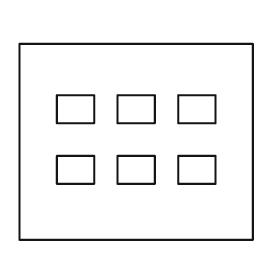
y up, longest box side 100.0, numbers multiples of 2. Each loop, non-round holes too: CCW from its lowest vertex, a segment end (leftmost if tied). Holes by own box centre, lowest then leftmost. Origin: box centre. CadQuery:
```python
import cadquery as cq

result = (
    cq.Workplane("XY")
    .moveTo(-50.0, -42.0)
    .lineTo(50.0, -42.0)
    .lineTo(50.0, 42.0)
    .lineTo(-50.0, 42.0)
    .close()
    .moveTo(-34.0, -18.0)
    .lineTo(-18.0, -18.0)
    .lineTo(-18.0, -6.0)
    .lineTo(-34.0, -6.0)
    .close()
    .moveTo(-8.0, -18.0)
    .lineTo(8.0, -18.0)
    .lineTo(8.0, -6.0)
    .lineTo(-8.0, -6.0)
    .close()
    .moveTo(18.0, -18.0)
    .lineTo(34.0, -18.0)
    .lineTo(34.0, -6.0)
    .lineTo(18.0, -6.0)
    .close()
    .moveTo(-34.0, 8.0)
    .lineTo(-18.0, 8.0)
    .lineTo(-18.0, 20.0)
    .lineTo(-34.0, 20.0)
    .close()
    .moveTo(-8.0, 8.0)
    .lineTo(8.0, 8.0)
    .lineTo(8.0, 20.0)
    .lineTo(-8.0, 20.0)
    .close()
    .moveTo(18.0, 8.0)
    .lineTo(34.0, 8.0)
    .lineTo(34.0, 20.0)
    .lineTo(18.0, 20.0)
    .close()
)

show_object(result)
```